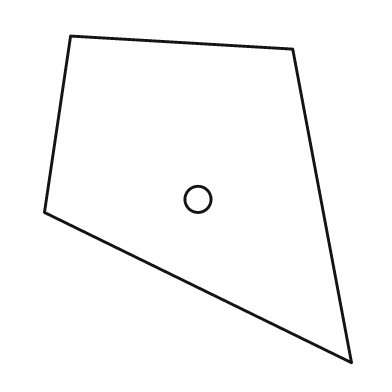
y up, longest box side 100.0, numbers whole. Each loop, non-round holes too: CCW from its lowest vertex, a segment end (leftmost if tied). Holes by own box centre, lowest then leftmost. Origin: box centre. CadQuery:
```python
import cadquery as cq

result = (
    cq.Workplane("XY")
    .moveTo(47.0, -50.0)
    .lineTo(29.0, 46.0)
    .lineTo(-39.0, 50.0)
    .lineTo(-47.0, -4.0)
    .close()
    .moveTo(0.0, 0.0)
    .circle(4.0)
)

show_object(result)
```